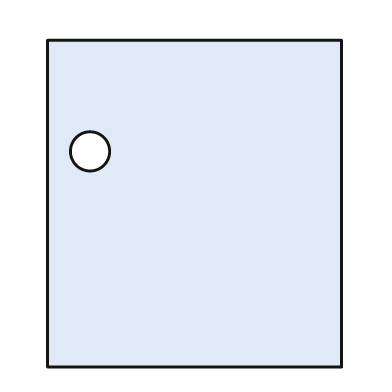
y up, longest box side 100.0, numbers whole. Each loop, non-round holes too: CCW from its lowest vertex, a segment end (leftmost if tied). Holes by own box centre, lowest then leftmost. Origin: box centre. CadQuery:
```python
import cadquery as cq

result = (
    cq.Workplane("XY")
    .moveTo(-45.0, -50.0)
    .lineTo(45.0, -50.0)
    .lineTo(45.0, 50.0)
    .lineTo(-45.0, 50.0)
    .close()
    .moveTo(-32.0, 16.0)
    .circle(6.0)
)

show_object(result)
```